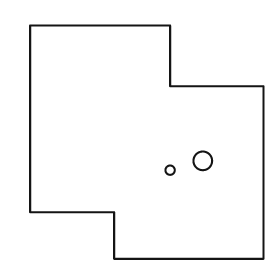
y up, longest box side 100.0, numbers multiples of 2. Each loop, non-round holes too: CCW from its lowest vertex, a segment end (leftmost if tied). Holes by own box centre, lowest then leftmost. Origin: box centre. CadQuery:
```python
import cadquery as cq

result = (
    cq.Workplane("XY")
    .moveTo(-14.0, -50.0)
    .lineTo(50.0, -50.0)
    .lineTo(50.0, 24.0)
    .lineTo(10.0, 24.0)
    .lineTo(10.0, 50.0)
    .lineTo(-50.0, 50.0)
    .lineTo(-50.0, -30.0)
    .lineTo(-14.0, -30.0)
    .close()
    .moveTo(10.0, -12.0)
    .circle(2.0)
    .moveTo(24.0, -8.0)
    .circle(4.0)
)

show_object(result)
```